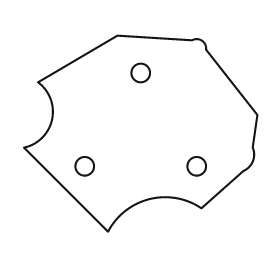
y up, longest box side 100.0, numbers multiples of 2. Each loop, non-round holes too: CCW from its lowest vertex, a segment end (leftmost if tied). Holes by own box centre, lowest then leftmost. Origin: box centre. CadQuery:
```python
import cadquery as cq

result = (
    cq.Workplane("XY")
    .moveTo(-14.0, -42.0)
    .threePointArc((4.0, -28.0), (26.0, -32.0))
    .lineTo(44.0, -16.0)
    .threePointArc((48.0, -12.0), (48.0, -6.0))
    .lineTo(50.0, 8.0)
    .lineTo(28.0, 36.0)
    .threePointArc((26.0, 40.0), (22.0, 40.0))
    .lineTo(-10.0, 42.0)
    .lineTo(-44.0, 22.0)
    .threePointArc((-38.0, 6.0), (-50.0, -6.0))
    .close()
    .moveTo(-24.0, -14.0)
    .circle(4.0)
    .moveTo(24.0, -14.0)
    .circle(4.0)
    .moveTo(0.0, 26.0)
    .circle(4.0)
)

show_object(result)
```